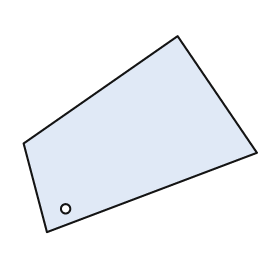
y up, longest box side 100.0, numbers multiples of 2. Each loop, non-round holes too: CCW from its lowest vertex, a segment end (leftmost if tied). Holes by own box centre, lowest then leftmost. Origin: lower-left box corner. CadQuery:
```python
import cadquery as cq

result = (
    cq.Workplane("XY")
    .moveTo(10.0, 0.0)
    .lineTo(100.0, 34.0)
    .lineTo(66.0, 84.0)
    .lineTo(0.0, 38.0)
    .close()
    .moveTo(18.0, 10.0)
    .circle(2.0)
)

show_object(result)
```